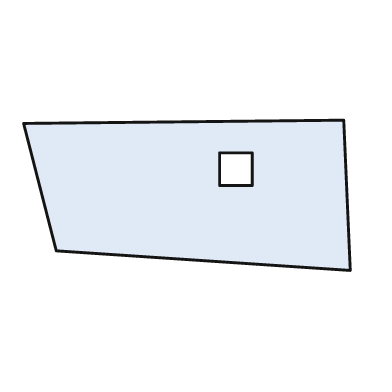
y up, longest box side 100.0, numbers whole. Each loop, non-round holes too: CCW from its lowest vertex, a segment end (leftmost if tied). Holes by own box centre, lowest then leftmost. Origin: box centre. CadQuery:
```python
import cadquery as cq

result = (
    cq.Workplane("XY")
    .moveTo(50.0, -23.0)
    .lineTo(48.0, 23.0)
    .lineTo(-50.0, 22.0)
    .lineTo(-40.0, -17.0)
    .close()
    .moveTo(10.0, 3.0)
    .lineTo(20.0, 3.0)
    .lineTo(20.0, 13.0)
    .lineTo(10.0, 13.0)
    .close()
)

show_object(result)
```